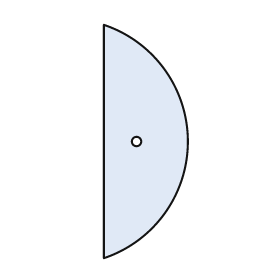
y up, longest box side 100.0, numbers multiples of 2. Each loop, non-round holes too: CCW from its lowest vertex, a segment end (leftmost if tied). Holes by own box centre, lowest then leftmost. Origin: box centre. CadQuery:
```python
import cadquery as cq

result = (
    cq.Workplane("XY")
    .moveTo(-18.0, -50.0)
    .threePointArc((18.0, 0.0), (-18.0, 50.0))
    .close()
    .moveTo(-4.0, 0.0)
    .circle(2.0)
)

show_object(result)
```